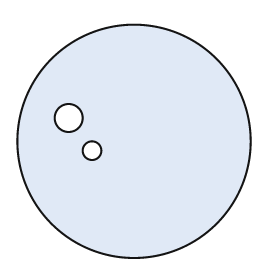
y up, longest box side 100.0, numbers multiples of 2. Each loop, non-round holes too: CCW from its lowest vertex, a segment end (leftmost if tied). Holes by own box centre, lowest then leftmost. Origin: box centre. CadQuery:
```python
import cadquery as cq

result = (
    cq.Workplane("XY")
    .moveTo(0.0, 0.0)
    .circle(50.0)
    .moveTo(-18.0, -4.0)
    .circle(4.0)
    .moveTo(-28.0, 10.0)
    .circle(6.0)
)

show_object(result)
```